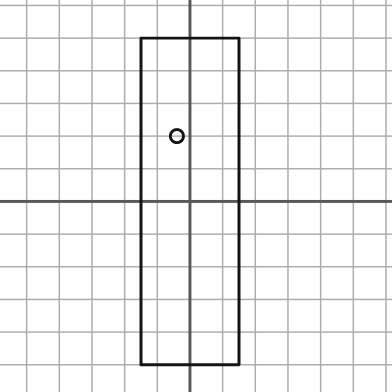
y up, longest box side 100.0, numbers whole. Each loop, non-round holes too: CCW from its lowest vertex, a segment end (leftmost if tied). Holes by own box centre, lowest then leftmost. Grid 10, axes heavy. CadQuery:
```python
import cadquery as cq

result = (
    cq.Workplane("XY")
    .moveTo(-15.0, -50.0)
    .lineTo(15.0, -50.0)
    .lineTo(15.0, 50.0)
    .lineTo(-15.0, 50.0)
    .close()
    .moveTo(-4.0, 20.0)
    .circle(2.0)
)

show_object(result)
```